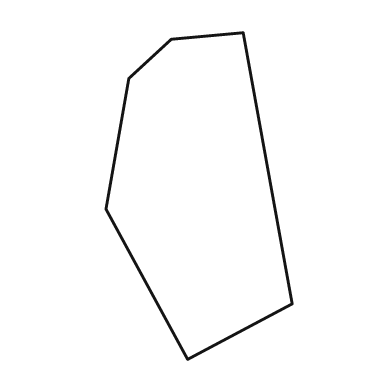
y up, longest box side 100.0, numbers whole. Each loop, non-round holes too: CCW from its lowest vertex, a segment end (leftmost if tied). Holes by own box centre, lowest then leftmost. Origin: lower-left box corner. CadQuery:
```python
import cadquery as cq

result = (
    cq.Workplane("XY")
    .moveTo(25.0, 0.0)
    .lineTo(57.0, 17.0)
    .lineTo(42.0, 100.0)
    .lineTo(20.0, 98.0)
    .lineTo(7.0, 86.0)
    .lineTo(0.0, 46.0)
    .close()
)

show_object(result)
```